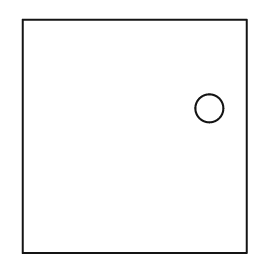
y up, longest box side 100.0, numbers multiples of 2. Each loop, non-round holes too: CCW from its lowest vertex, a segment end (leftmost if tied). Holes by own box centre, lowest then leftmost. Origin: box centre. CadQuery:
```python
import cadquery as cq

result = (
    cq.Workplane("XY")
    .moveTo(-48.0, -50.0)
    .lineTo(48.0, -50.0)
    .lineTo(48.0, 50.0)
    .lineTo(-48.0, 50.0)
    .close()
    .moveTo(32.0, 12.0)
    .circle(6.0)
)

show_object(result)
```